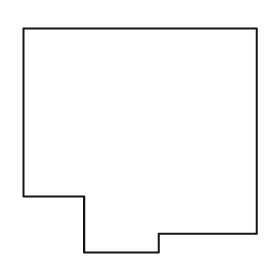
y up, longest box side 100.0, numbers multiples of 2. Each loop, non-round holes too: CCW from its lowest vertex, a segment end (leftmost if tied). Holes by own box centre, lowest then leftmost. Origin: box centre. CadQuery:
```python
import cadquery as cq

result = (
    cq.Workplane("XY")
    .moveTo(-24.0, -48.0)
    .lineTo(8.0, -48.0)
    .lineTo(8.0, -40.0)
    .lineTo(50.0, -40.0)
    .lineTo(50.0, 48.0)
    .lineTo(-50.0, 48.0)
    .lineTo(-50.0, -24.0)
    .lineTo(-24.0, -24.0)
    .close()
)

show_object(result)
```